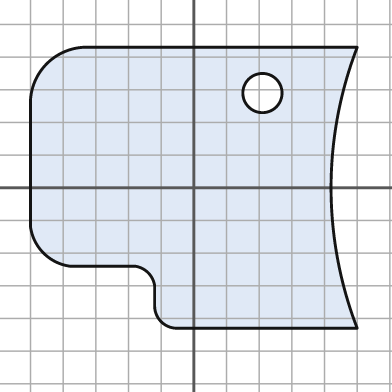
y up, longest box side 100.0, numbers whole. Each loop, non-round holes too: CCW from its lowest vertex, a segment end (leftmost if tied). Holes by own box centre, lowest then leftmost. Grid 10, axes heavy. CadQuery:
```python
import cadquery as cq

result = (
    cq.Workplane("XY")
    .moveTo(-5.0, -43.0)
    .lineTo(50.0, -43.0)
    .threePointArc((42.0, 0.0), (50.0, 43.0))
    .lineTo(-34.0, 43.0)
    .threePointArc((-45.0, 38.0), (-50.0, 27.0))
    .lineTo(-50.0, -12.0)
    .threePointArc((-46.0, -20.0), (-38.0, -24.0))
    .lineTo(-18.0, -24.0)
    .threePointArc((-14.0, -26.0), (-12.0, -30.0))
    .lineTo(-12.0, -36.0)
    .threePointArc((-10.0, -41.0), (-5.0, -43.0))
    .close()
    .moveTo(21.0, 29.0)
    .circle(6.0)
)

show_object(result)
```